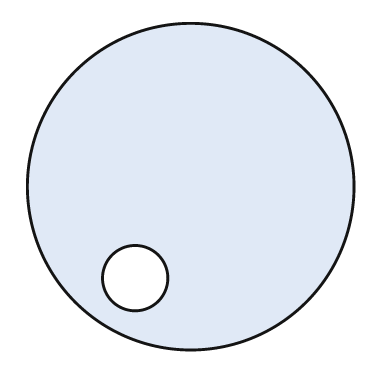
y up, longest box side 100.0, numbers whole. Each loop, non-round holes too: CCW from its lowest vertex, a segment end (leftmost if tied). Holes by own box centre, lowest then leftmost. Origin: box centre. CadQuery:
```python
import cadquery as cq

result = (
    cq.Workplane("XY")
    .moveTo(0.0, 0.0)
    .circle(50.0)
    .moveTo(-17.0, -28.0)
    .circle(10.0)
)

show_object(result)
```